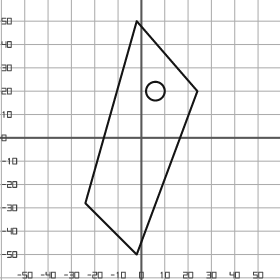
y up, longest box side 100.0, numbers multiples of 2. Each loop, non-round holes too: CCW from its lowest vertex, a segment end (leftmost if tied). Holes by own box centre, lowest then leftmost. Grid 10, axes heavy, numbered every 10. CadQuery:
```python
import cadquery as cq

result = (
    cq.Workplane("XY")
    .moveTo(-2.0, -50.0)
    .lineTo(24.0, 20.0)
    .lineTo(-2.0, 50.0)
    .lineTo(-24.0, -28.0)
    .close()
    .moveTo(6.0, 20.0)
    .circle(4.0)
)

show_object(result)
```